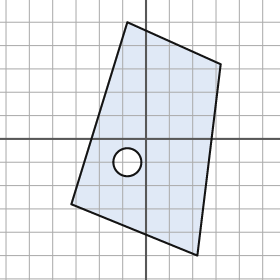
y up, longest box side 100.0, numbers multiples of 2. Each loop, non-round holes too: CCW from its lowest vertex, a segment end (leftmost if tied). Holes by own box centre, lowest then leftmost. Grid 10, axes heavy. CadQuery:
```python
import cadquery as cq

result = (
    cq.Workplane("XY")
    .moveTo(22.0, -50.0)
    .lineTo(32.0, 32.0)
    .lineTo(-8.0, 50.0)
    .lineTo(-32.0, -28.0)
    .close()
    .moveTo(-8.0, -10.0)
    .circle(6.0)
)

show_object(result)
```